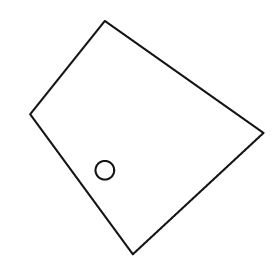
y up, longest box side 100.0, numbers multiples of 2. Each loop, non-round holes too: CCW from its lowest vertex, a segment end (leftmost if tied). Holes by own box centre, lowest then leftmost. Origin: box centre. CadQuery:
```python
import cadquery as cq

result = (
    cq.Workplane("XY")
    .moveTo(-6.0, -50.0)
    .lineTo(50.0, 2.0)
    .lineTo(-18.0, 50.0)
    .lineTo(-50.0, 10.0)
    .close()
    .moveTo(-18.0, -14.0)
    .circle(4.0)
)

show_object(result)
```